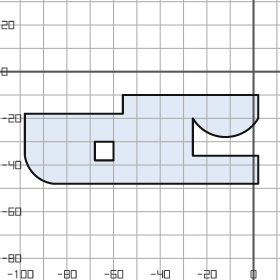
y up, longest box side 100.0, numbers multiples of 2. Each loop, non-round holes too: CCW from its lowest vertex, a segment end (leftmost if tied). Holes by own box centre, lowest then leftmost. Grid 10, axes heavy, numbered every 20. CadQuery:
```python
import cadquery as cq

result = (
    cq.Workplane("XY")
    .moveTo(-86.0, -48.0)
    .lineTo(2.0, -48.0)
    .lineTo(2.0, -36.0)
    .lineTo(-26.0, -36.0)
    .lineTo(-26.0, -20.0)
    .threePointArc((-12.0, -28.0), (2.0, -20.0))
    .lineTo(2.0, -10.0)
    .lineTo(-56.0, -10.0)
    .lineTo(-56.0, -18.0)
    .lineTo(-98.0, -18.0)
    .lineTo(-98.0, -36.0)
    .threePointArc((-94.0, -44.0), (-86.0, -48.0))
    .close()
    .moveTo(-68.0, -38.0)
    .lineTo(-60.0, -38.0)
    .lineTo(-60.0, -30.0)
    .lineTo(-68.0, -30.0)
    .close()
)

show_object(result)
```